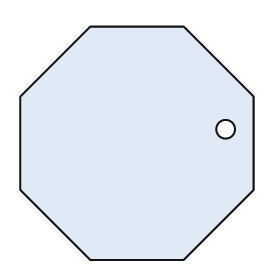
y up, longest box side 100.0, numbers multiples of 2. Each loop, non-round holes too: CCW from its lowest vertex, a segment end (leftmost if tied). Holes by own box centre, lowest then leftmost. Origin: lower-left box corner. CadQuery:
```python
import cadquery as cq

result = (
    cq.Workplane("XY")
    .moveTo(30.0, 0.0)
    .lineTo(70.0, 0.0)
    .lineTo(100.0, 30.0)
    .lineTo(100.0, 70.0)
    .lineTo(70.0, 100.0)
    .lineTo(30.0, 100.0)
    .lineTo(0.0, 70.0)
    .lineTo(0.0, 30.0)
    .close()
    .moveTo(88.0, 56.0)
    .circle(4.0)
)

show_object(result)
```